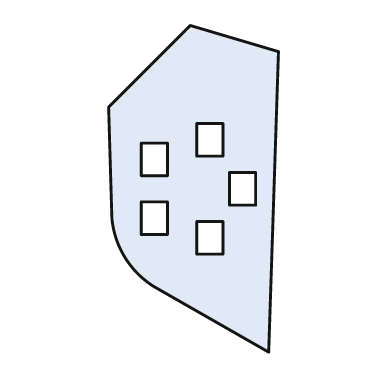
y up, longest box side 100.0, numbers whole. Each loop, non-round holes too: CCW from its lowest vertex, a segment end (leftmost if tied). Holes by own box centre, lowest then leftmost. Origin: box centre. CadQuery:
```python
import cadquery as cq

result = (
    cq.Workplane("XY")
    .moveTo(23.0, -50.0)
    .lineTo(26.0, 42.0)
    .lineTo(-1.0, 50.0)
    .lineTo(-26.0, 25.0)
    .lineTo(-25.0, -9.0)
    .threePointArc((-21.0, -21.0), (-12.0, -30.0))
    .close()
    .moveTo(1.0, -20.0)
    .lineTo(9.0, -20.0)
    .lineTo(9.0, -10.0)
    .lineTo(1.0, -10.0)
    .close()
    .moveTo(-16.0, -14.0)
    .lineTo(-8.0, -14.0)
    .lineTo(-8.0, -4.0)
    .lineTo(-16.0, -4.0)
    .close()
    .moveTo(11.0, -5.0)
    .lineTo(19.0, -5.0)
    .lineTo(19.0, 5.0)
    .lineTo(11.0, 5.0)
    .close()
    .moveTo(-16.0, 4.0)
    .lineTo(-8.0, 4.0)
    .lineTo(-8.0, 14.0)
    .lineTo(-16.0, 14.0)
    .close()
    .moveTo(1.0, 10.0)
    .lineTo(9.0, 10.0)
    .lineTo(9.0, 20.0)
    .lineTo(1.0, 20.0)
    .close()
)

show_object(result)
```